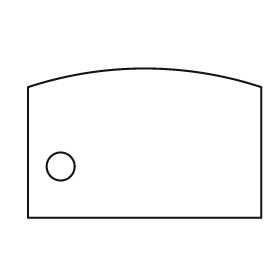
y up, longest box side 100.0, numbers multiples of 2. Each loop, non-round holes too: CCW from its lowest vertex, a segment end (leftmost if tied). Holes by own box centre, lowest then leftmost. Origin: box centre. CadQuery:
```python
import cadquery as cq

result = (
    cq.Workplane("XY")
    .moveTo(-50.0, -32.0)
    .lineTo(50.0, -32.0)
    .lineTo(50.0, 24.0)
    .threePointArc((0.0, 32.0), (-50.0, 24.0))
    .close()
    .moveTo(-36.0, -10.0)
    .circle(6.0)
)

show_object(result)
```